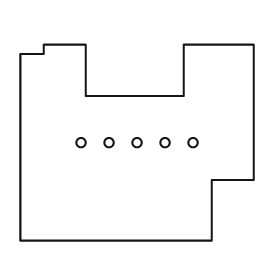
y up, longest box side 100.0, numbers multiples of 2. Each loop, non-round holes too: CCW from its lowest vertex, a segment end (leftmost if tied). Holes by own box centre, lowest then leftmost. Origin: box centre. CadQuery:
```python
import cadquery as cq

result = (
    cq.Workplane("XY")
    .moveTo(-50.0, -42.0)
    .lineTo(32.0, -42.0)
    .lineTo(32.0, -16.0)
    .lineTo(50.0, -16.0)
    .lineTo(50.0, 42.0)
    .lineTo(20.0, 42.0)
    .lineTo(20.0, 20.0)
    .lineTo(-22.0, 20.0)
    .lineTo(-22.0, 42.0)
    .lineTo(-40.0, 42.0)
    .lineTo(-40.0, 38.0)
    .lineTo(-50.0, 38.0)
    .close()
    .moveTo(-24.0, 0.0)
    .circle(2.0)
    .moveTo(-12.0, 0.0)
    .circle(2.0)
    .moveTo(0.0, 0.0)
    .circle(2.0)
    .moveTo(12.0, 0.0)
    .circle(2.0)
    .moveTo(24.0, 0.0)
    .circle(2.0)
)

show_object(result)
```